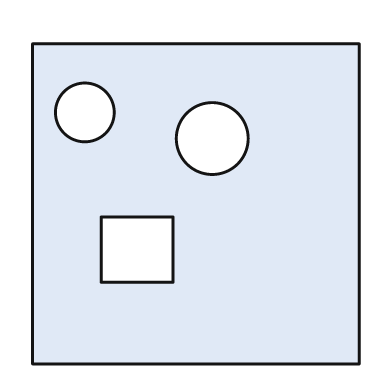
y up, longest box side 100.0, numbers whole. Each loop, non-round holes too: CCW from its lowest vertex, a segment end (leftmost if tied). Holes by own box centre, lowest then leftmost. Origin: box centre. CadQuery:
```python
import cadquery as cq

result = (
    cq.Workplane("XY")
    .moveTo(-50.0, -49.0)
    .lineTo(50.0, -49.0)
    .lineTo(50.0, 49.0)
    .lineTo(-50.0, 49.0)
    .close()
    .moveTo(-29.0, -24.0)
    .lineTo(-7.0, -24.0)
    .lineTo(-7.0, -4.0)
    .lineTo(-29.0, -4.0)
    .close()
    .moveTo(5.0, 20.0)
    .circle(11.0)
    .moveTo(-34.0, 28.0)
    .circle(9.0)
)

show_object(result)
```